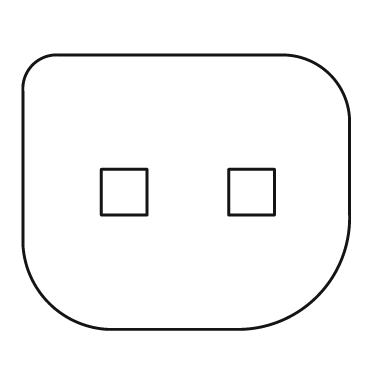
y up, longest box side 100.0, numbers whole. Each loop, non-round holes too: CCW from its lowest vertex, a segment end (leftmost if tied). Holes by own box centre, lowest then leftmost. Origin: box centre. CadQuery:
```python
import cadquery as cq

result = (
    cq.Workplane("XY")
    .moveTo(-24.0, -42.0)
    .lineTo(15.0, -42.0)
    .threePointArc((40.0, -32.0), (50.0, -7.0))
    .lineTo(50.0, 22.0)
    .threePointArc((44.0, 36.0), (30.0, 42.0))
    .lineTo(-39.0, 42.0)
    .threePointArc((-47.0, 39.0), (-50.0, 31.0))
    .lineTo(-50.0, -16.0)
    .threePointArc((-42.0, -34.0), (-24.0, -42.0))
    .close()
    .moveTo(-26.0, -7.0)
    .lineTo(-12.0, -7.0)
    .lineTo(-12.0, 7.0)
    .lineTo(-26.0, 7.0)
    .close()
    .moveTo(13.0, -7.0)
    .lineTo(27.0, -7.0)
    .lineTo(27.0, 7.0)
    .lineTo(13.0, 7.0)
    .close()
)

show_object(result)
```